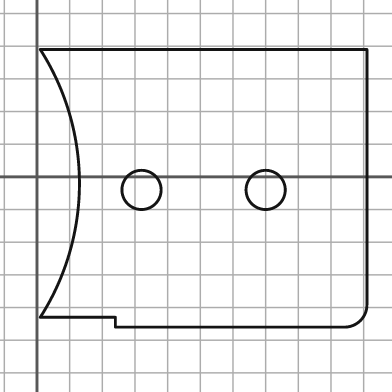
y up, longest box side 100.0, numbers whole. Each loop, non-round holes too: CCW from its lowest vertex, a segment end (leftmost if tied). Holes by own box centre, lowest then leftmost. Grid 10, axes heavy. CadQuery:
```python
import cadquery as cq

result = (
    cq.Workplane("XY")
    .moveTo(24.0, -46.0)
    .lineTo(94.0, -46.0)
    .threePointArc((99.0, -44.0), (101.0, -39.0))
    .lineTo(101.0, 39.0)
    .lineTo(1.0, 39.0)
    .threePointArc((13.0, -2.0), (1.0, -43.0))
    .lineTo(24.0, -43.0)
    .close()
    .moveTo(32.0, -4.0)
    .circle(6.0)
    .moveTo(70.0, -4.0)
    .circle(6.0)
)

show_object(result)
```